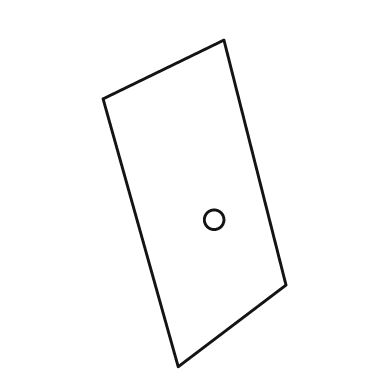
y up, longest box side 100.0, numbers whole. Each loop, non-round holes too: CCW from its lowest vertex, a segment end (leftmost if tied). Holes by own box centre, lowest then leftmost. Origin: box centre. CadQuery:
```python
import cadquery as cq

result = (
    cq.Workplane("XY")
    .moveTo(-5.0, -50.0)
    .lineTo(28.0, -25.0)
    .lineTo(9.0, 50.0)
    .lineTo(-28.0, 32.0)
    .close()
    .moveTo(6.0, -5.0)
    .circle(3.0)
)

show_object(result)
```